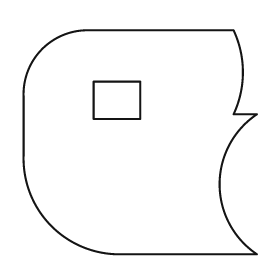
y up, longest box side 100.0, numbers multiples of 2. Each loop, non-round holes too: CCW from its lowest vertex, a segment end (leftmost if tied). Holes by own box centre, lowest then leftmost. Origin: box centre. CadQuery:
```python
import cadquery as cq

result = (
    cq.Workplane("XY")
    .moveTo(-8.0, -48.0)
    .lineTo(50.0, -48.0)
    .threePointArc((34.0, -18.0), (50.0, 12.0))
    .lineTo(40.0, 12.0)
    .threePointArc((44.0, 30.0), (40.0, 48.0))
    .lineTo(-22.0, 48.0)
    .threePointArc((-42.0, 40.0), (-50.0, 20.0))
    .lineTo(-50.0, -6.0)
    .threePointArc((-38.0, -36.0), (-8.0, -48.0))
    .close()
    .moveTo(-20.0, 10.0)
    .lineTo(0.0, 10.0)
    .lineTo(0.0, 26.0)
    .lineTo(-20.0, 26.0)
    .close()
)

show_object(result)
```